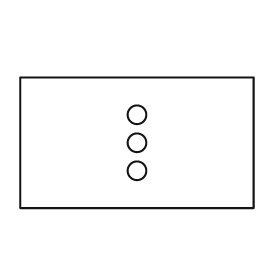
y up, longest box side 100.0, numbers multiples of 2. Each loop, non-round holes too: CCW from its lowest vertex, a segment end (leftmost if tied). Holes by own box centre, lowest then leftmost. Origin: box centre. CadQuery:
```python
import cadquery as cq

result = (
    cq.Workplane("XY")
    .moveTo(-50.0, -28.0)
    .lineTo(50.0, -28.0)
    .lineTo(50.0, 28.0)
    .lineTo(-50.0, 28.0)
    .close()
    .moveTo(0.0, -12.0)
    .circle(4.0)
    .moveTo(0.0, 0.0)
    .circle(4.0)
    .moveTo(0.0, 12.0)
    .circle(4.0)
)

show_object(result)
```